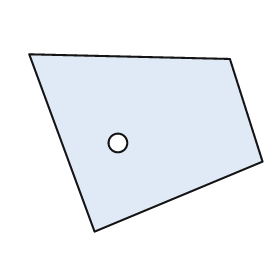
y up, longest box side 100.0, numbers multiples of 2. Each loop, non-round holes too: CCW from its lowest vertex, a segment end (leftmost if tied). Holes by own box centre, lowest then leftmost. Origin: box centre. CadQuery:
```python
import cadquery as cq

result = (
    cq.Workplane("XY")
    .moveTo(-22.0, -38.0)
    .lineTo(50.0, -8.0)
    .lineTo(36.0, 36.0)
    .lineTo(-50.0, 38.0)
    .close()
    .moveTo(-12.0, 0.0)
    .circle(4.0)
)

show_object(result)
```